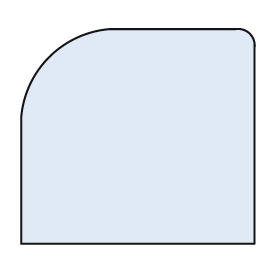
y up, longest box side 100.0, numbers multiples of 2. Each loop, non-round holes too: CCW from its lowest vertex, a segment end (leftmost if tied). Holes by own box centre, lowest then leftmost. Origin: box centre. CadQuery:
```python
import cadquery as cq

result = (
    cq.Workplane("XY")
    .moveTo(-50.0, -46.0)
    .lineTo(50.0, -46.0)
    .lineTo(50.0, 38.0)
    .threePointArc((48.0, 44.0), (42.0, 46.0))
    .lineTo(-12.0, 46.0)
    .threePointArc((-38.0, 34.0), (-50.0, 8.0))
    .close()
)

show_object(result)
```